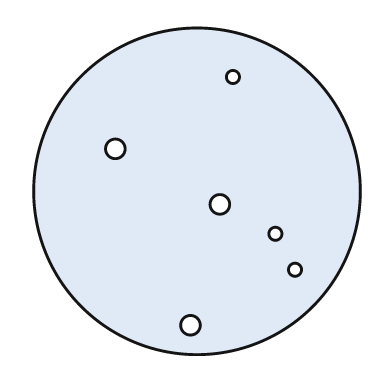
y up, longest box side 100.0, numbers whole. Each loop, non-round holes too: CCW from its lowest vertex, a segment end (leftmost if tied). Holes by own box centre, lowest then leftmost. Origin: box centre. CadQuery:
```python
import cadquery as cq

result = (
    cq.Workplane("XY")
    .moveTo(0.0, 0.0)
    .circle(50.0)
    .moveTo(-2.0, -41.0)
    .circle(3.0)
    .moveTo(30.0, -24.0)
    .circle(2.0)
    .moveTo(24.0, -13.0)
    .circle(2.0)
    .moveTo(7.0, -4.0)
    .circle(3.0)
    .moveTo(-25.0, 13.0)
    .circle(3.0)
    .moveTo(11.0, 35.0)
    .circle(2.0)
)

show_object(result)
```